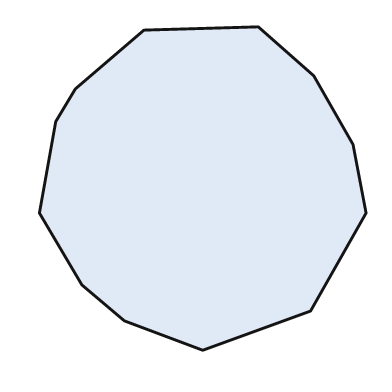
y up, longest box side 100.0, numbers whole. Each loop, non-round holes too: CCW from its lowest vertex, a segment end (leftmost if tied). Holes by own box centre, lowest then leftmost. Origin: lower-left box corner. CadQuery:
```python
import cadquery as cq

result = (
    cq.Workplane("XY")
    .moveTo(50.0, 0.0)
    .lineTo(83.0, 12.0)
    .lineTo(100.0, 42.0)
    .lineTo(96.0, 63.0)
    .lineTo(84.0, 84.0)
    .lineTo(67.0, 99.0)
    .lineTo(32.0, 98.0)
    .lineTo(11.0, 80.0)
    .lineTo(5.0, 70.0)
    .lineTo(0.0, 42.0)
    .lineTo(13.0, 20.0)
    .lineTo(26.0, 9.0)
    .close()
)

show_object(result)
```